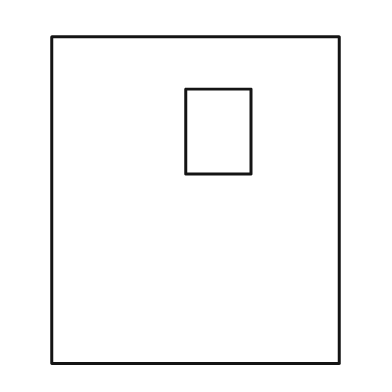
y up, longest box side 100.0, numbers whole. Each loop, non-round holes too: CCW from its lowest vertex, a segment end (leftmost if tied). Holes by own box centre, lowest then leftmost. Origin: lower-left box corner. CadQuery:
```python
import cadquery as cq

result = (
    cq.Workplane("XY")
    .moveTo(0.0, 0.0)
    .lineTo(88.0, 0.0)
    .lineTo(88.0, 100.0)
    .lineTo(0.0, 100.0)
    .close()
    .moveTo(41.0, 58.0)
    .lineTo(61.0, 58.0)
    .lineTo(61.0, 84.0)
    .lineTo(41.0, 84.0)
    .close()
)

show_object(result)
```